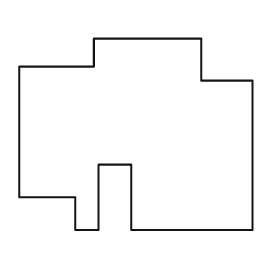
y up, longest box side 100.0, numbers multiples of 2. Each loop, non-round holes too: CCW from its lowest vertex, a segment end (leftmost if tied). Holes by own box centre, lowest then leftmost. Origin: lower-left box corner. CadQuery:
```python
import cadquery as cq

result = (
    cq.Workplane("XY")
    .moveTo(24.0, 0.0)
    .lineTo(34.0, 0.0)
    .lineTo(34.0, 28.0)
    .lineTo(48.0, 28.0)
    .lineTo(48.0, 0.0)
    .lineTo(100.0, 0.0)
    .lineTo(100.0, 64.0)
    .lineTo(78.0, 64.0)
    .lineTo(78.0, 82.0)
    .lineTo(32.0, 82.0)
    .lineTo(32.0, 70.0)
    .lineTo(0.0, 70.0)
    .lineTo(0.0, 14.0)
    .lineTo(24.0, 14.0)
    .close()
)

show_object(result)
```